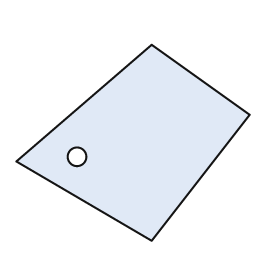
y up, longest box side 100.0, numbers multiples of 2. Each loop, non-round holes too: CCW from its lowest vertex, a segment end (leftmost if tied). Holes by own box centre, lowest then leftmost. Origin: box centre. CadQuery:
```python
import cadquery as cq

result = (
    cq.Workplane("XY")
    .moveTo(8.0, -42.0)
    .lineTo(50.0, 12.0)
    .lineTo(8.0, 42.0)
    .lineTo(-50.0, -8.0)
    .close()
    .moveTo(-24.0, -6.0)
    .circle(4.0)
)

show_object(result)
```